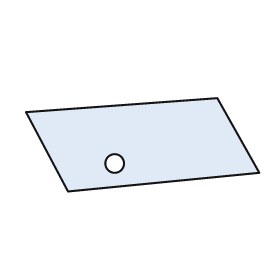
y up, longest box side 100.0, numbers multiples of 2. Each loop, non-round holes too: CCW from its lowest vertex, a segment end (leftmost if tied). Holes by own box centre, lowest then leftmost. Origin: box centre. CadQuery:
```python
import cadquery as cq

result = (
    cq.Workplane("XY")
    .moveTo(-32.0, -20.0)
    .lineTo(50.0, -12.0)
    .lineTo(32.0, 20.0)
    .lineTo(-50.0, 14.0)
    .close()
    .moveTo(-12.0, -8.0)
    .circle(4.0)
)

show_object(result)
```